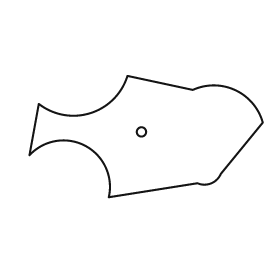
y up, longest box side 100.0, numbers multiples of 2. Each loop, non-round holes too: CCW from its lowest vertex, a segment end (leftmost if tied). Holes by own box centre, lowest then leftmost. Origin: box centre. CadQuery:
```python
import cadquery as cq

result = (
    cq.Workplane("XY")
    .moveTo(-16.0, -26.0)
    .lineTo(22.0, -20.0)
    .threePointArc((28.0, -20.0), (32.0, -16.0))
    .lineTo(50.0, 6.0)
    .threePointArc((38.0, 20.0), (20.0, 20.0))
    .lineTo(-8.0, 26.0)
    .threePointArc((-24.0, 10.0), (-46.0, 14.0))
    .lineTo(-50.0, -8.0)
    .threePointArc((-26.0, -4.0), (-16.0, -26.0))
    .close()
    .moveTo(-2.0, 2.0)
    .circle(2.0)
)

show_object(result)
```